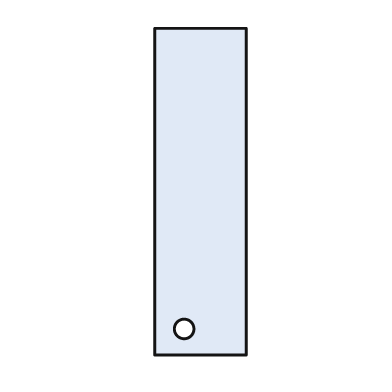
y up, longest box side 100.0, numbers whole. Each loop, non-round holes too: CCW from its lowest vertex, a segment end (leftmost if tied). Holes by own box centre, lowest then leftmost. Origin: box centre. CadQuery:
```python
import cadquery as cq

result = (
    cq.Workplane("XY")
    .moveTo(-14.0, -50.0)
    .lineTo(14.0, -50.0)
    .lineTo(14.0, 50.0)
    .lineTo(-14.0, 50.0)
    .close()
    .moveTo(-5.0, -42.0)
    .circle(3.0)
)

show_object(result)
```